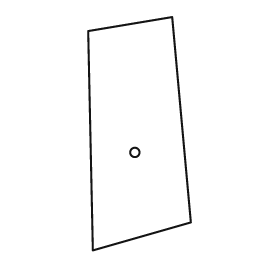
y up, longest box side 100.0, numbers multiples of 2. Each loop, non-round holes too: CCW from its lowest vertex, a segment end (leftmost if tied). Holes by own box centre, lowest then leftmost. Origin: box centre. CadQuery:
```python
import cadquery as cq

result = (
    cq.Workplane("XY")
    .moveTo(-20.0, -50.0)
    .lineTo(22.0, -38.0)
    .lineTo(14.0, 50.0)
    .lineTo(-22.0, 44.0)
    .close()
    .moveTo(-2.0, -8.0)
    .circle(2.0)
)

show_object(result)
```